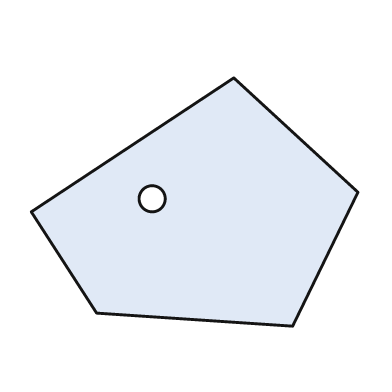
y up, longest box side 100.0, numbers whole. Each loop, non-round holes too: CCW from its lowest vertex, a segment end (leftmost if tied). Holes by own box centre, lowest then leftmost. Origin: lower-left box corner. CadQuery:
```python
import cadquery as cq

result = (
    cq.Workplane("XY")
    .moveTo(80.0, 0.0)
    .lineTo(100.0, 41.0)
    .lineTo(62.0, 76.0)
    .lineTo(0.0, 35.0)
    .lineTo(20.0, 4.0)
    .close()
    .moveTo(37.0, 39.0)
    .circle(4.0)
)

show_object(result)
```